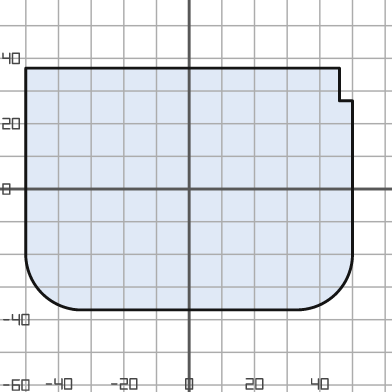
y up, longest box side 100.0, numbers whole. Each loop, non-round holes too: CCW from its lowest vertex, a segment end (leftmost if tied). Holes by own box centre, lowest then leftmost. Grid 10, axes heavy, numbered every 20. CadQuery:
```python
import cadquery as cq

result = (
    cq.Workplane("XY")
    .moveTo(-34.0, -37.0)
    .lineTo(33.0, -37.0)
    .threePointArc((45.0, -32.0), (50.0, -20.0))
    .lineTo(50.0, 27.0)
    .lineTo(46.0, 27.0)
    .lineTo(46.0, 37.0)
    .lineTo(-50.0, 37.0)
    .lineTo(-50.0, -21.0)
    .threePointArc((-45.0, -32.0), (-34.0, -37.0))
    .close()
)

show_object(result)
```